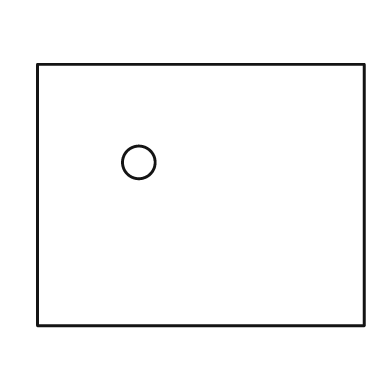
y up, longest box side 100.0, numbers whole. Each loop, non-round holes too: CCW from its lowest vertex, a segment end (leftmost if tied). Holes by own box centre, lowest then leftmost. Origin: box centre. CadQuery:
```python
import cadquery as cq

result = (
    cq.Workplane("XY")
    .moveTo(-50.0, -40.0)
    .lineTo(50.0, -40.0)
    .lineTo(50.0, 40.0)
    .lineTo(-50.0, 40.0)
    .close()
    .moveTo(-19.0, 10.0)
    .circle(5.0)
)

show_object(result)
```